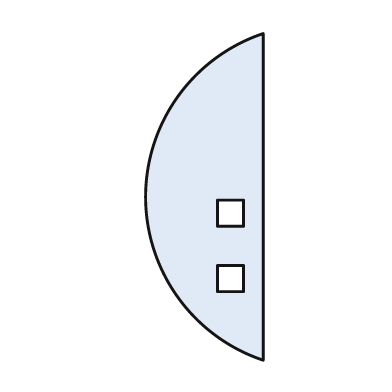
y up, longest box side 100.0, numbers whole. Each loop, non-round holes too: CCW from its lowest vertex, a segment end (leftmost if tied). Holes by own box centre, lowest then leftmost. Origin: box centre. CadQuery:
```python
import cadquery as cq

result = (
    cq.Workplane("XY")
    .moveTo(18.0, -50.0)
    .lineTo(18.0, 50.0)
    .threePointArc((-18.0, 0.0), (18.0, -50.0))
    .close()
    .moveTo(4.0, -29.0)
    .lineTo(12.0, -29.0)
    .lineTo(12.0, -21.0)
    .lineTo(4.0, -21.0)
    .close()
    .moveTo(4.0, -9.0)
    .lineTo(12.0, -9.0)
    .lineTo(12.0, -1.0)
    .lineTo(4.0, -1.0)
    .close()
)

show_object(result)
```